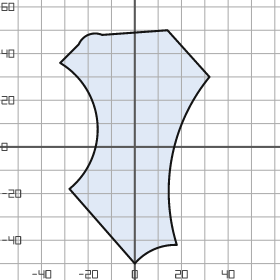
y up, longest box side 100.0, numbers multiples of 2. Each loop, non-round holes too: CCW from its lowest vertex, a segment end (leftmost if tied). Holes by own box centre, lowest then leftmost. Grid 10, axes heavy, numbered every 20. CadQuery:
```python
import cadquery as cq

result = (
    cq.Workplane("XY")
    .moveTo(0.0, -50.0)
    .threePointArc((8.0, -44.0), (18.0, -42.0))
    .threePointArc((16.0, -4.0), (32.0, 30.0))
    .lineTo(14.0, 50.0)
    .lineTo(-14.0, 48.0)
    .threePointArc((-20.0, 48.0), (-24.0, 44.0))
    .lineTo(-32.0, 36.0)
    .threePointArc((-16.0, 10.0), (-28.0, -18.0))
    .close()
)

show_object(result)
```